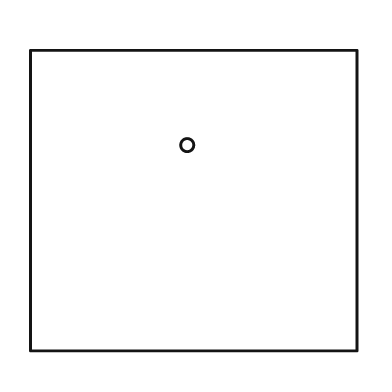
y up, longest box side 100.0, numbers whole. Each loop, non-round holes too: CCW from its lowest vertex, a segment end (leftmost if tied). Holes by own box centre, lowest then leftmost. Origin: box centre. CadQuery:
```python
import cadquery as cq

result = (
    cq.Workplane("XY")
    .moveTo(-50.0, -46.0)
    .lineTo(50.0, -46.0)
    .lineTo(50.0, 46.0)
    .lineTo(-50.0, 46.0)
    .close()
    .moveTo(-2.0, 17.0)
    .circle(2.0)
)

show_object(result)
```